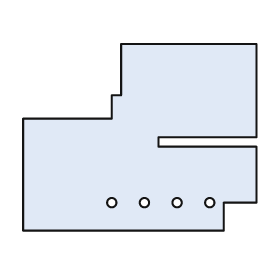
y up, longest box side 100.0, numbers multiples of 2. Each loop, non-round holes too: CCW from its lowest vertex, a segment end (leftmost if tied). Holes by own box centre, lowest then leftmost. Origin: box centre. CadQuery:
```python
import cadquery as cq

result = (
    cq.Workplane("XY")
    .moveTo(-50.0, -40.0)
    .lineTo(36.0, -40.0)
    .lineTo(36.0, -28.0)
    .lineTo(50.0, -28.0)
    .lineTo(50.0, -4.0)
    .lineTo(8.0, -4.0)
    .lineTo(8.0, 0.0)
    .lineTo(50.0, 0.0)
    .lineTo(50.0, 40.0)
    .lineTo(-8.0, 40.0)
    .lineTo(-8.0, 18.0)
    .lineTo(-12.0, 18.0)
    .lineTo(-12.0, 8.0)
    .lineTo(-50.0, 8.0)
    .close()
    .moveTo(-12.0, -28.0)
    .circle(2.0)
    .moveTo(2.0, -28.0)
    .circle(2.0)
    .moveTo(16.0, -28.0)
    .circle(2.0)
    .moveTo(30.0, -28.0)
    .circle(2.0)
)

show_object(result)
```